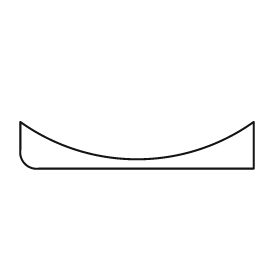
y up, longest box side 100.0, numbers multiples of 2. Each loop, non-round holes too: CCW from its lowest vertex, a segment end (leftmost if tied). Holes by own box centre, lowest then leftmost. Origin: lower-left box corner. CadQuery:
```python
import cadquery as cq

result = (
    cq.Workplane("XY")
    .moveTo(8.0, 0.0)
    .lineTo(100.0, 0.0)
    .lineTo(100.0, 20.0)
    .threePointArc((50.0, 4.0), (0.0, 20.0))
    .lineTo(0.0, 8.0)
    .threePointArc((2.0, 2.0), (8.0, 0.0))
    .close()
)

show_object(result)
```